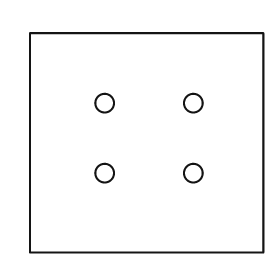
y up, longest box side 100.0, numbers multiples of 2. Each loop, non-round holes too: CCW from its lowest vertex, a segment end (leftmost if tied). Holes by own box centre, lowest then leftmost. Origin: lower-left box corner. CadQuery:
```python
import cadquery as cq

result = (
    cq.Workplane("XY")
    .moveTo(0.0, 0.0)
    .lineTo(100.0, 0.0)
    .lineTo(100.0, 94.0)
    .lineTo(0.0, 94.0)
    .close()
    .moveTo(32.0, 34.0)
    .circle(4.0)
    .moveTo(70.0, 34.0)
    .circle(4.0)
    .moveTo(32.0, 64.0)
    .circle(4.0)
    .moveTo(70.0, 64.0)
    .circle(4.0)
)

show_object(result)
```